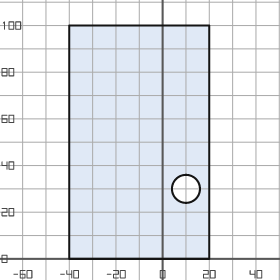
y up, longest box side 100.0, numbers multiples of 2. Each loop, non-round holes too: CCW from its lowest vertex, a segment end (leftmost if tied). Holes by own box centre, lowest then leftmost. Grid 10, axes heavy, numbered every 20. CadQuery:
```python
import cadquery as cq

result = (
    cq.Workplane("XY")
    .moveTo(-40.0, 0.0)
    .lineTo(20.0, 0.0)
    .lineTo(20.0, 100.0)
    .lineTo(-40.0, 100.0)
    .close()
    .moveTo(10.0, 30.0)
    .circle(6.0)
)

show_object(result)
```